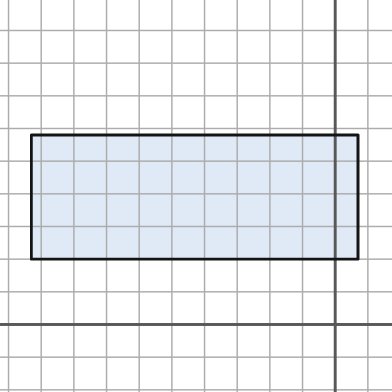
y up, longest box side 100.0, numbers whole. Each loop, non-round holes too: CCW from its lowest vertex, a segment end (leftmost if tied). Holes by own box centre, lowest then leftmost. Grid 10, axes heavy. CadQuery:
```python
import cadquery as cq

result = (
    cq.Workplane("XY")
    .moveTo(-93.0, 20.0)
    .lineTo(7.0, 20.0)
    .lineTo(7.0, 58.0)
    .lineTo(-93.0, 58.0)
    .close()
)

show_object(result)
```